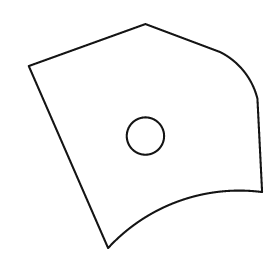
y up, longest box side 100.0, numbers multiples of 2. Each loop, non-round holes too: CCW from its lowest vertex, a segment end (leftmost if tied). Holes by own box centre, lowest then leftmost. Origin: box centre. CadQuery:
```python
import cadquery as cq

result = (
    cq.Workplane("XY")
    .moveTo(-16.0, -48.0)
    .threePointArc((14.0, -28.0), (50.0, -24.0))
    .lineTo(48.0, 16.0)
    .threePointArc((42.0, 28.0), (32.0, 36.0))
    .lineTo(0.0, 48.0)
    .lineTo(-50.0, 30.0)
    .close()
    .moveTo(0.0, 0.0)
    .circle(8.0)
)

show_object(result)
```